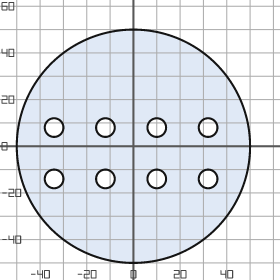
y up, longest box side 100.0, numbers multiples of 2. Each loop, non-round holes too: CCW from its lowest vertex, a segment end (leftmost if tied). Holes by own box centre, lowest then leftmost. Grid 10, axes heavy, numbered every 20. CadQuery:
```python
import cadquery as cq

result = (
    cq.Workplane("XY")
    .moveTo(0.0, 0.0)
    .circle(50.0)
    .moveTo(-34.0, -14.0)
    .circle(4.0)
    .moveTo(-12.0, -14.0)
    .circle(4.0)
    .moveTo(10.0, -14.0)
    .circle(4.0)
    .moveTo(32.0, -14.0)
    .circle(4.0)
    .moveTo(-34.0, 8.0)
    .circle(4.0)
    .moveTo(-12.0, 8.0)
    .circle(4.0)
    .moveTo(10.0, 8.0)
    .circle(4.0)
    .moveTo(32.0, 8.0)
    .circle(4.0)
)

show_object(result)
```